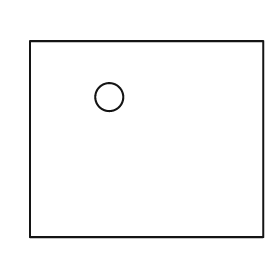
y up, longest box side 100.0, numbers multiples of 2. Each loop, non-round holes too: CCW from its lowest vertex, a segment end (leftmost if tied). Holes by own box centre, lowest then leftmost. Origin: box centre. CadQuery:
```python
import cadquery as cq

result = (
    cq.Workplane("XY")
    .moveTo(-50.0, -42.0)
    .lineTo(50.0, -42.0)
    .lineTo(50.0, 42.0)
    .lineTo(-50.0, 42.0)
    .close()
    .moveTo(-16.0, 18.0)
    .circle(6.0)
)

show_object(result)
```